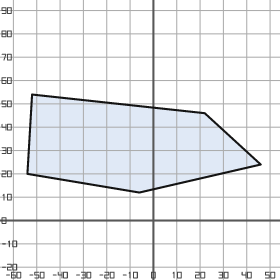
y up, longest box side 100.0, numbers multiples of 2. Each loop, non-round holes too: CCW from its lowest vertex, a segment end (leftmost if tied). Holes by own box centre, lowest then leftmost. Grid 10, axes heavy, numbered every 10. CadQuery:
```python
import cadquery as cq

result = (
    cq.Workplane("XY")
    .moveTo(-6.0, 12.0)
    .lineTo(46.0, 24.0)
    .lineTo(22.0, 46.0)
    .lineTo(-52.0, 54.0)
    .lineTo(-54.0, 20.0)
    .close()
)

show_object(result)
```